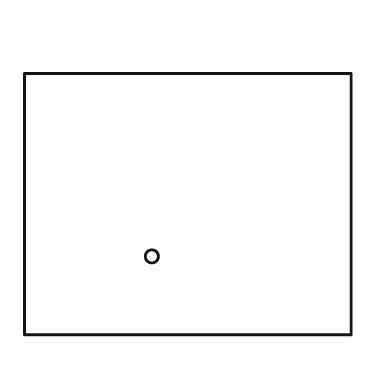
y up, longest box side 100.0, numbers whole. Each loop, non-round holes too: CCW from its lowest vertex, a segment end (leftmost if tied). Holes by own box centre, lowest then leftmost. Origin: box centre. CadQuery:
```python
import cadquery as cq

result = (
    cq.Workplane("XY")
    .moveTo(-50.0, -40.0)
    .lineTo(50.0, -40.0)
    .lineTo(50.0, 40.0)
    .lineTo(-50.0, 40.0)
    .close()
    .moveTo(-11.0, -16.0)
    .circle(2.0)
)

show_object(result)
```